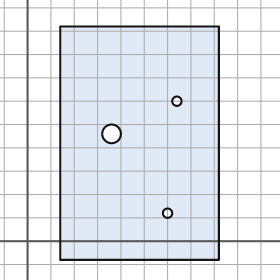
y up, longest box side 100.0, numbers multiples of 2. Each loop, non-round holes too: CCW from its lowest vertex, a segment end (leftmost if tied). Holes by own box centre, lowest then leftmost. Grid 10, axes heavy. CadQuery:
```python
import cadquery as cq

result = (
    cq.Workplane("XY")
    .moveTo(14.0, -8.0)
    .lineTo(82.0, -8.0)
    .lineTo(82.0, 92.0)
    .lineTo(14.0, 92.0)
    .close()
    .moveTo(60.0, 12.0)
    .circle(2.0)
    .moveTo(36.0, 46.0)
    .circle(4.0)
    .moveTo(64.0, 60.0)
    .circle(2.0)
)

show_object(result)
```